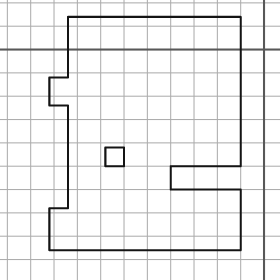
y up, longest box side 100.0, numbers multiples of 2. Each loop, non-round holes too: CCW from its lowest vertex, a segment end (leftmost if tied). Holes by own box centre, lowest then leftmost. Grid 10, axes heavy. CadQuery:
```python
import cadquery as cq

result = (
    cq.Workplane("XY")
    .moveTo(-92.0, -86.0)
    .lineTo(-10.0, -86.0)
    .lineTo(-10.0, -60.0)
    .lineTo(-40.0, -60.0)
    .lineTo(-40.0, -50.0)
    .lineTo(-10.0, -50.0)
    .lineTo(-10.0, 14.0)
    .lineTo(-84.0, 14.0)
    .lineTo(-84.0, -12.0)
    .lineTo(-92.0, -12.0)
    .lineTo(-92.0, -24.0)
    .lineTo(-84.0, -24.0)
    .lineTo(-84.0, -68.0)
    .lineTo(-92.0, -68.0)
    .close()
    .moveTo(-68.0, -50.0)
    .lineTo(-60.0, -50.0)
    .lineTo(-60.0, -42.0)
    .lineTo(-68.0, -42.0)
    .close()
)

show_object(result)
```